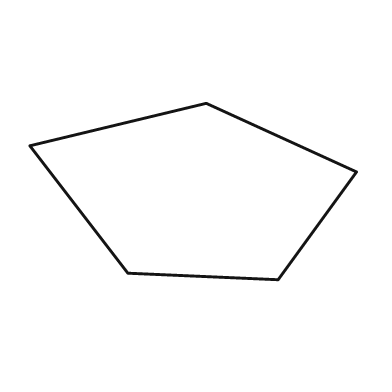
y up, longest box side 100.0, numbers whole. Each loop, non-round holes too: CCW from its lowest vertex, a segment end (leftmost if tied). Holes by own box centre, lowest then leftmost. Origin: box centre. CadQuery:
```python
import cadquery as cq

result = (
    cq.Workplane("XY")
    .moveTo(26.0, -27.0)
    .lineTo(50.0, 6.0)
    .lineTo(4.0, 27.0)
    .lineTo(-50.0, 14.0)
    .lineTo(-20.0, -25.0)
    .close()
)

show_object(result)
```